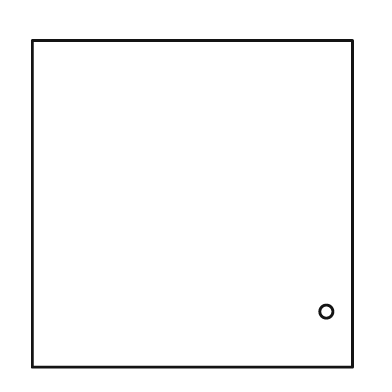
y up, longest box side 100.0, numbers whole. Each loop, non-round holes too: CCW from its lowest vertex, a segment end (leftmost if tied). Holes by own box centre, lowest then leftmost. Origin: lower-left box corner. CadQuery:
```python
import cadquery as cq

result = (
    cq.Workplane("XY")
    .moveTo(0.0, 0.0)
    .lineTo(98.0, 0.0)
    .lineTo(98.0, 100.0)
    .lineTo(0.0, 100.0)
    .close()
    .moveTo(90.0, 17.0)
    .circle(2.0)
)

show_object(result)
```